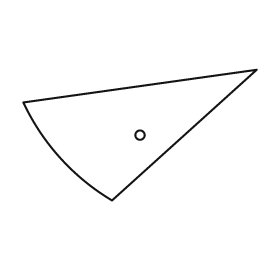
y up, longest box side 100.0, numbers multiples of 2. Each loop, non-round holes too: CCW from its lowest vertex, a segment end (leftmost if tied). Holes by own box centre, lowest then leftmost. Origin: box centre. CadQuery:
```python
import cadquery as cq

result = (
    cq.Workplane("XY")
    .moveTo(-12.0, -28.0)
    .lineTo(50.0, 28.0)
    .lineTo(-50.0, 14.0)
    .threePointArc((-34.0, -10.0), (-12.0, -28.0))
    .close()
    .moveTo(0.0, 0.0)
    .circle(2.0)
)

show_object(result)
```